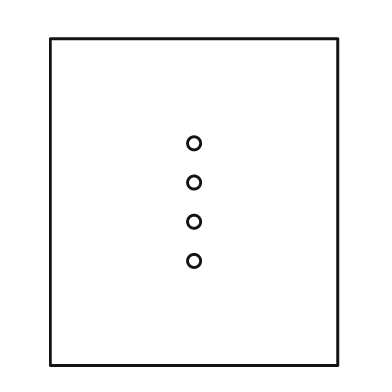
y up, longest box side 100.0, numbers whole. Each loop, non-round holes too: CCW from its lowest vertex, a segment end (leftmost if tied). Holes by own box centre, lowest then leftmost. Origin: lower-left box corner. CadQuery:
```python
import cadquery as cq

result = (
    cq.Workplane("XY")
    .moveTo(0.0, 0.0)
    .lineTo(88.0, 0.0)
    .lineTo(88.0, 100.0)
    .lineTo(0.0, 100.0)
    .close()
    .moveTo(44.0, 32.0)
    .circle(2.0)
    .moveTo(44.0, 44.0)
    .circle(2.0)
    .moveTo(44.0, 56.0)
    .circle(2.0)
    .moveTo(44.0, 68.0)
    .circle(2.0)
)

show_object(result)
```